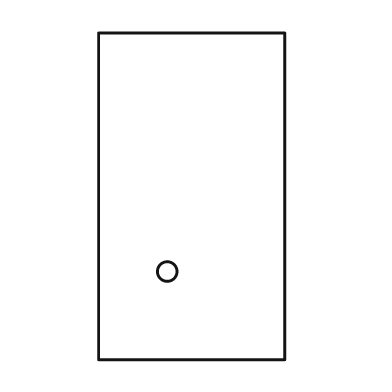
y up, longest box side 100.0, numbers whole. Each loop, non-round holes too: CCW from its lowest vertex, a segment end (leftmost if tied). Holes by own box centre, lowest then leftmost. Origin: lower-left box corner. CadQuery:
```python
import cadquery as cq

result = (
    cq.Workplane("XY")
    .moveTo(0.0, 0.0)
    .lineTo(57.0, 0.0)
    .lineTo(57.0, 100.0)
    .lineTo(0.0, 100.0)
    .close()
    .moveTo(21.0, 27.0)
    .circle(3.0)
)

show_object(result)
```